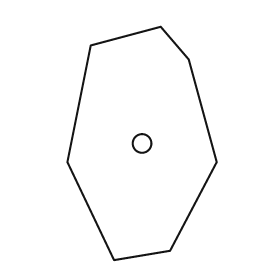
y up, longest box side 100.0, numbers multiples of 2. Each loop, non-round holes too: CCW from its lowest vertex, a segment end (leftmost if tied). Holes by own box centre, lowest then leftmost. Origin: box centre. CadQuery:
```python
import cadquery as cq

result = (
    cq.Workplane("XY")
    .moveTo(-12.0, -50.0)
    .lineTo(12.0, -46.0)
    .lineTo(32.0, -8.0)
    .lineTo(20.0, 36.0)
    .lineTo(8.0, 50.0)
    .lineTo(-22.0, 42.0)
    .lineTo(-32.0, -8.0)
    .close()
    .moveTo(0.0, 0.0)
    .circle(4.0)
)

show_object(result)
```